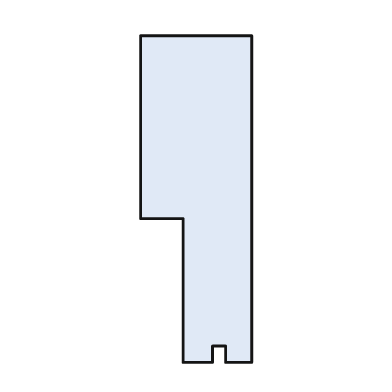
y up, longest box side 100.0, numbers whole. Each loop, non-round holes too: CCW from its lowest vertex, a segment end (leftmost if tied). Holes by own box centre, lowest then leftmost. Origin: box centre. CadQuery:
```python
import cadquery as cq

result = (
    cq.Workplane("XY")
    .moveTo(-4.0, -50.0)
    .lineTo(5.0, -50.0)
    .lineTo(5.0, -45.0)
    .lineTo(9.0, -45.0)
    .lineTo(9.0, -50.0)
    .lineTo(17.0, -50.0)
    .lineTo(17.0, 50.0)
    .lineTo(-17.0, 50.0)
    .lineTo(-17.0, -6.0)
    .lineTo(-4.0, -6.0)
    .close()
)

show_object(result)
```